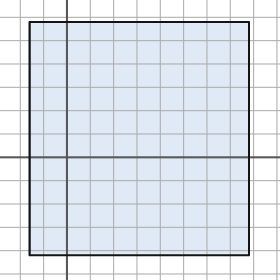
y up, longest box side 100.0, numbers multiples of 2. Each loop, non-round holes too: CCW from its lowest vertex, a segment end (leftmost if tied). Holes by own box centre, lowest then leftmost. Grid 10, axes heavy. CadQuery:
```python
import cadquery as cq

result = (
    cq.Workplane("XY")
    .moveTo(-16.0, -42.0)
    .lineTo(78.0, -42.0)
    .lineTo(78.0, 58.0)
    .lineTo(-16.0, 58.0)
    .close()
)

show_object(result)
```